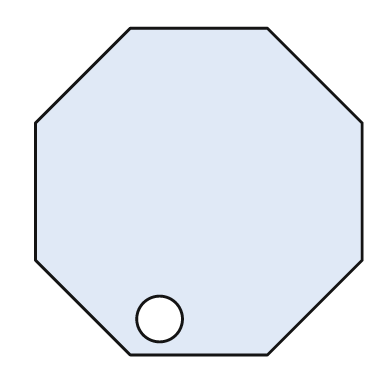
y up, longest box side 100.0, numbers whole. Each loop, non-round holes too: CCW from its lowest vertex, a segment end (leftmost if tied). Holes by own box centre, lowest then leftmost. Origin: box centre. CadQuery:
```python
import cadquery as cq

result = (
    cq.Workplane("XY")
    .moveTo(-21.0, -50.0)
    .lineTo(21.0, -50.0)
    .lineTo(50.0, -21.0)
    .lineTo(50.0, 21.0)
    .lineTo(21.0, 50.0)
    .lineTo(-21.0, 50.0)
    .lineTo(-50.0, 21.0)
    .lineTo(-50.0, -21.0)
    .close()
    .moveTo(-12.0, -39.0)
    .circle(7.0)
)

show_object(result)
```